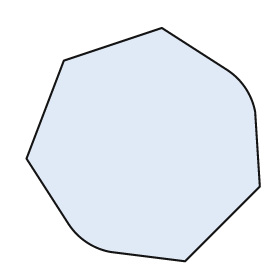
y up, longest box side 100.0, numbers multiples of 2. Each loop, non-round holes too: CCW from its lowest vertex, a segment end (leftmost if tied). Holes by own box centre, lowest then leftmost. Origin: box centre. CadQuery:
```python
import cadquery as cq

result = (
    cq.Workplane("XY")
    .moveTo(18.0, -50.0)
    .lineTo(50.0, -18.0)
    .lineTo(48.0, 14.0)
    .threePointArc((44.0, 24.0), (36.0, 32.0))
    .lineTo(8.0, 50.0)
    .lineTo(-34.0, 36.0)
    .lineTo(-50.0, -6.0)
    .lineTo(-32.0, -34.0)
    .threePointArc((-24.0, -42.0), (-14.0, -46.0))
    .close()
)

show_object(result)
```